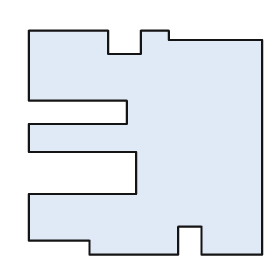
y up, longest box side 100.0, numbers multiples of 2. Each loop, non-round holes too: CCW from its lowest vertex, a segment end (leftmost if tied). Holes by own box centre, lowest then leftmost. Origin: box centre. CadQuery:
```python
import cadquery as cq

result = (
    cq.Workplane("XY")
    .moveTo(-24.0, -48.0)
    .lineTo(14.0, -48.0)
    .lineTo(14.0, -36.0)
    .lineTo(24.0, -36.0)
    .lineTo(24.0, -48.0)
    .lineTo(50.0, -48.0)
    .lineTo(50.0, 44.0)
    .lineTo(10.0, 44.0)
    .lineTo(10.0, 48.0)
    .lineTo(-2.0, 48.0)
    .lineTo(-2.0, 38.0)
    .lineTo(-16.0, 38.0)
    .lineTo(-16.0, 48.0)
    .lineTo(-50.0, 48.0)
    .lineTo(-50.0, 18.0)
    .lineTo(-8.0, 18.0)
    .lineTo(-8.0, 8.0)
    .lineTo(-50.0, 8.0)
    .lineTo(-50.0, -4.0)
    .lineTo(-4.0, -4.0)
    .lineTo(-4.0, -22.0)
    .lineTo(-50.0, -22.0)
    .lineTo(-50.0, -42.0)
    .lineTo(-24.0, -42.0)
    .close()
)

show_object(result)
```